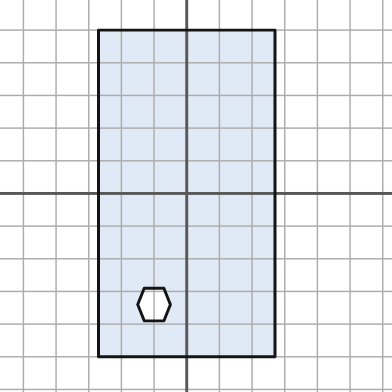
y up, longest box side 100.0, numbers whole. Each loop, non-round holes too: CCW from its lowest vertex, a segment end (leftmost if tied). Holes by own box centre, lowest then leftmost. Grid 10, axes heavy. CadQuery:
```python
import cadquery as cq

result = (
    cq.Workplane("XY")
    .moveTo(-27.0, -50.0)
    .lineTo(27.0, -50.0)
    .lineTo(27.0, 50.0)
    .lineTo(-27.0, 50.0)
    .close()
    .moveTo(-13.0, -39.0)
    .lineTo(-7.0, -39.0)
    .lineTo(-5.0, -34.0)
    .lineTo(-7.0, -29.0)
    .lineTo(-13.0, -29.0)
    .lineTo(-15.0, -34.0)
    .close()
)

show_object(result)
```